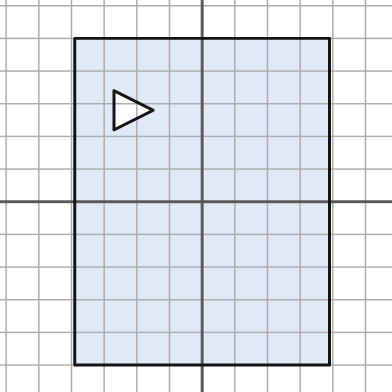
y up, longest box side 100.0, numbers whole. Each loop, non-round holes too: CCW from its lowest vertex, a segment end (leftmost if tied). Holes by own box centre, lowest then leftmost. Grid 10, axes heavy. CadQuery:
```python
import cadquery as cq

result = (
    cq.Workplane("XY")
    .moveTo(-39.0, -50.0)
    .lineTo(39.0, -50.0)
    .lineTo(39.0, 50.0)
    .lineTo(-39.0, 50.0)
    .close()
    .moveTo(-27.0, 22.0)
    .lineTo(-15.0, 28.0)
    .lineTo(-27.0, 34.0)
    .close()
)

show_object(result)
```